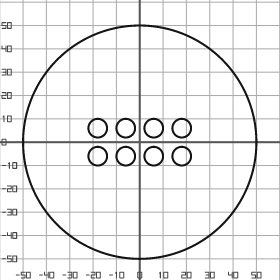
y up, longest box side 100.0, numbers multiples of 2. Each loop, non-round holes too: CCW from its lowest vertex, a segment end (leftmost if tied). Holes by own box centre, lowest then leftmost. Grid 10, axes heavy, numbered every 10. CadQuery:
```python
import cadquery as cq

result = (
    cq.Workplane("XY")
    .moveTo(0.0, 0.0)
    .circle(50.0)
    .moveTo(-18.0, -6.0)
    .circle(4.0)
    .moveTo(-6.0, -6.0)
    .circle(4.0)
    .moveTo(6.0, -6.0)
    .circle(4.0)
    .moveTo(18.0, -6.0)
    .circle(4.0)
    .moveTo(-18.0, 6.0)
    .circle(4.0)
    .moveTo(-6.0, 6.0)
    .circle(4.0)
    .moveTo(6.0, 6.0)
    .circle(4.0)
    .moveTo(18.0, 6.0)
    .circle(4.0)
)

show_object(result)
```